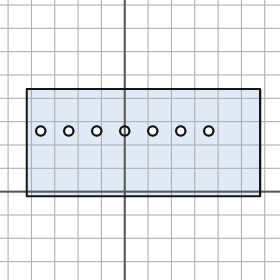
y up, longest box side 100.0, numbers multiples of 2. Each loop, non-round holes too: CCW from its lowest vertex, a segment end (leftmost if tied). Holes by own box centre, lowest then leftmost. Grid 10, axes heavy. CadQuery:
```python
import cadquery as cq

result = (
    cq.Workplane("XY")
    .moveTo(-42.0, -2.0)
    .lineTo(58.0, -2.0)
    .lineTo(58.0, 44.0)
    .lineTo(-42.0, 44.0)
    .close()
    .moveTo(-36.0, 26.0)
    .circle(2.0)
    .moveTo(-24.0, 26.0)
    .circle(2.0)
    .moveTo(-12.0, 26.0)
    .circle(2.0)
    .moveTo(0.0, 26.0)
    .circle(2.0)
    .moveTo(12.0, 26.0)
    .circle(2.0)
    .moveTo(24.0, 26.0)
    .circle(2.0)
    .moveTo(36.0, 26.0)
    .circle(2.0)
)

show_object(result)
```